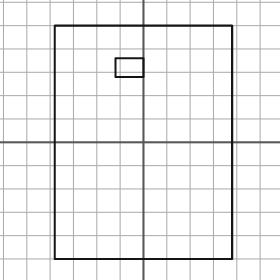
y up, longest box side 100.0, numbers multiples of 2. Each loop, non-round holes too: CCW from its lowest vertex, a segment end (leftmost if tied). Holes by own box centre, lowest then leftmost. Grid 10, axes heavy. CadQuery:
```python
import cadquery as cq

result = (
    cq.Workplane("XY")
    .moveTo(-38.0, -50.0)
    .lineTo(38.0, -50.0)
    .lineTo(38.0, 50.0)
    .lineTo(-38.0, 50.0)
    .close()
    .moveTo(-12.0, 28.0)
    .lineTo(0.0, 28.0)
    .lineTo(0.0, 36.0)
    .lineTo(-12.0, 36.0)
    .close()
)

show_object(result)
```